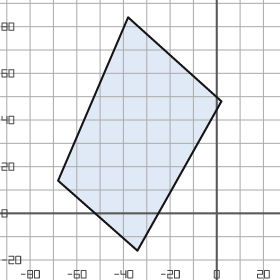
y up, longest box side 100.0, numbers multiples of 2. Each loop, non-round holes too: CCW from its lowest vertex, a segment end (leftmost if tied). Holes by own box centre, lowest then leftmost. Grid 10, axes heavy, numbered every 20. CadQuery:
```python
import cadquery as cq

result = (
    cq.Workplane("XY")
    .moveTo(-34.0, -16.0)
    .lineTo(2.0, 48.0)
    .lineTo(-38.0, 84.0)
    .lineTo(-68.0, 14.0)
    .close()
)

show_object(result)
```